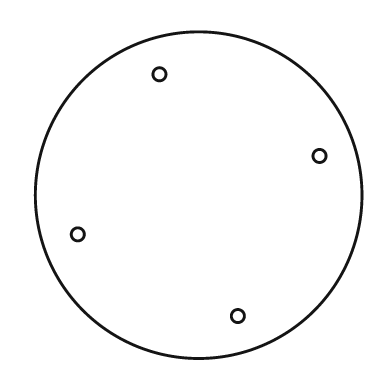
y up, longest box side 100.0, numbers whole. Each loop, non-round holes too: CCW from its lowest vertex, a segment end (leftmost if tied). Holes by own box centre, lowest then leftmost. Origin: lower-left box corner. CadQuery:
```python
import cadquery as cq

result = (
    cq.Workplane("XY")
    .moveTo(50.0, 50.0)
    .circle(50.0)
    .moveTo(62.0, 13.0)
    .circle(2.0)
    .moveTo(13.0, 38.0)
    .circle(2.0)
    .moveTo(87.0, 62.0)
    .circle(2.0)
    .moveTo(38.0, 87.0)
    .circle(2.0)
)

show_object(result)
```